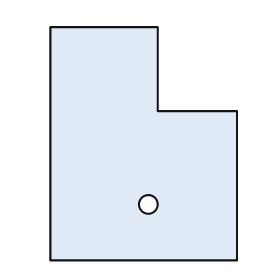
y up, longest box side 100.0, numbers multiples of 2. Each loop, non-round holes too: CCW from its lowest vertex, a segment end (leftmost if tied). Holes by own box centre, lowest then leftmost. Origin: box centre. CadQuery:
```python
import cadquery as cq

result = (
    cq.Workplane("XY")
    .moveTo(-40.0, -50.0)
    .lineTo(40.0, -50.0)
    .lineTo(40.0, 14.0)
    .lineTo(6.0, 14.0)
    .lineTo(6.0, 50.0)
    .lineTo(-40.0, 50.0)
    .close()
    .moveTo(2.0, -26.0)
    .circle(4.0)
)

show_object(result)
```